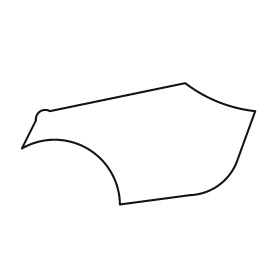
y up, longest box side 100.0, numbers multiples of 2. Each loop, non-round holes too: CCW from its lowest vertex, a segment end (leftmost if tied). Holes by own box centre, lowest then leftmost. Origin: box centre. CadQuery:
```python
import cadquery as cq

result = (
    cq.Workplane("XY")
    .moveTo(-8.0, -26.0)
    .lineTo(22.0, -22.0)
    .threePointArc((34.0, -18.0), (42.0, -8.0))
    .lineTo(50.0, 14.0)
    .threePointArc((34.0, 18.0), (20.0, 26.0))
    .lineTo(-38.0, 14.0)
    .threePointArc((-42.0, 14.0), (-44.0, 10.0))
    .lineTo(-50.0, -2.0)
    .threePointArc((-22.0, -2.0), (-8.0, -26.0))
    .close()
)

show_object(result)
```